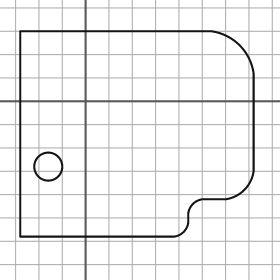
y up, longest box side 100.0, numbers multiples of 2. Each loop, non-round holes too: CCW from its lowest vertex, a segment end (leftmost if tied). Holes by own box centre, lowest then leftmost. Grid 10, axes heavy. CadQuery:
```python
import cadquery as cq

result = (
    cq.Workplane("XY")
    .moveTo(-28.0, -58.0)
    .lineTo(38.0, -58.0)
    .threePointArc((42.0, -56.0), (44.0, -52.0))
    .lineTo(44.0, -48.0)
    .threePointArc((46.0, -44.0), (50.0, -42.0))
    .lineTo(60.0, -42.0)
    .threePointArc((68.0, -38.0), (72.0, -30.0))
    .lineTo(72.0, 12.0)
    .threePointArc((66.0, 24.0), (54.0, 30.0))
    .lineTo(-28.0, 30.0)
    .close()
    .moveTo(-16.0, -28.0)
    .circle(6.0)
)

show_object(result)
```